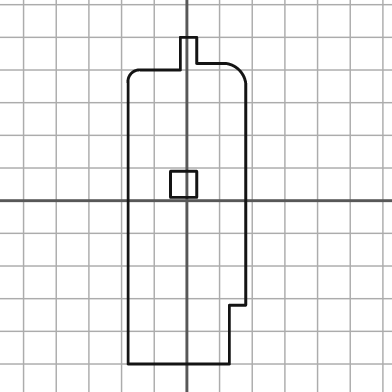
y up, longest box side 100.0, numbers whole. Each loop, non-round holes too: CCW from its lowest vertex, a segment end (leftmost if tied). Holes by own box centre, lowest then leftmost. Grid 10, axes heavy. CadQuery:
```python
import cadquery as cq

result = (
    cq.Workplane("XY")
    .moveTo(-18.0, -50.0)
    .lineTo(13.0, -50.0)
    .lineTo(13.0, -32.0)
    .lineTo(18.0, -32.0)
    .lineTo(18.0, 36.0)
    .threePointArc((16.0, 40.0), (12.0, 42.0))
    .lineTo(3.0, 42.0)
    .lineTo(3.0, 50.0)
    .lineTo(-2.0, 50.0)
    .lineTo(-2.0, 40.0)
    .lineTo(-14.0, 40.0)
    .threePointArc((-17.0, 39.0), (-18.0, 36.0))
    .close()
    .moveTo(-5.0, 1.0)
    .lineTo(3.0, 1.0)
    .lineTo(3.0, 9.0)
    .lineTo(-5.0, 9.0)
    .close()
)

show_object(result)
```